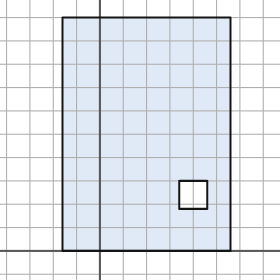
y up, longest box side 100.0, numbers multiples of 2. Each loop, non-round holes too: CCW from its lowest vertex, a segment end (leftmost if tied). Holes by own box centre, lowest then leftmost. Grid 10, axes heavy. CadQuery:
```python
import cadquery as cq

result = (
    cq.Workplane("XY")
    .moveTo(-16.0, 0.0)
    .lineTo(56.0, 0.0)
    .lineTo(56.0, 100.0)
    .lineTo(-16.0, 100.0)
    .close()
    .moveTo(34.0, 18.0)
    .lineTo(46.0, 18.0)
    .lineTo(46.0, 30.0)
    .lineTo(34.0, 30.0)
    .close()
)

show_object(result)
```